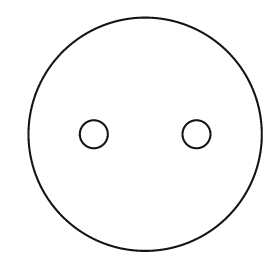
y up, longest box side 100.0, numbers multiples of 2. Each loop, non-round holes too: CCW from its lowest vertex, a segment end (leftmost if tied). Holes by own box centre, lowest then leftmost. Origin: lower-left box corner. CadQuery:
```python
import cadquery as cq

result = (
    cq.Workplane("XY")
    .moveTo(50.0, 50.0)
    .circle(50.0)
    .moveTo(28.0, 50.0)
    .circle(6.0)
    .moveTo(72.0, 50.0)
    .circle(6.0)
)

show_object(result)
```